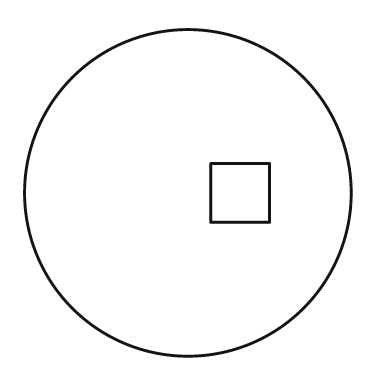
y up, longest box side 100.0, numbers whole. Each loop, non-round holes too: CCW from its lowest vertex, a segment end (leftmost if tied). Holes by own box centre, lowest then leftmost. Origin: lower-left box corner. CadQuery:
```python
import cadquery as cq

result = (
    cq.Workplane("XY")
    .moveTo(50.0, 50.0)
    .circle(50.0)
    .moveTo(57.0, 41.0)
    .lineTo(75.0, 41.0)
    .lineTo(75.0, 59.0)
    .lineTo(57.0, 59.0)
    .close()
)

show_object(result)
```